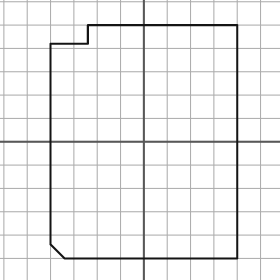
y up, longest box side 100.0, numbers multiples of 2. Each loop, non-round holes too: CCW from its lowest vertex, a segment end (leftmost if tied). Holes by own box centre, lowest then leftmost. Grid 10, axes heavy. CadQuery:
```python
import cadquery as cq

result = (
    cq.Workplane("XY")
    .moveTo(-34.0, -50.0)
    .lineTo(40.0, -50.0)
    .lineTo(40.0, 50.0)
    .lineTo(-24.0, 50.0)
    .lineTo(-24.0, 42.0)
    .lineTo(-40.0, 42.0)
    .lineTo(-40.0, -44.0)
    .close()
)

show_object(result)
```